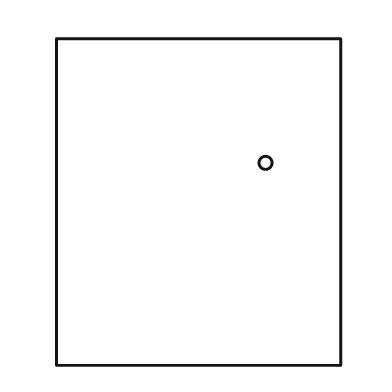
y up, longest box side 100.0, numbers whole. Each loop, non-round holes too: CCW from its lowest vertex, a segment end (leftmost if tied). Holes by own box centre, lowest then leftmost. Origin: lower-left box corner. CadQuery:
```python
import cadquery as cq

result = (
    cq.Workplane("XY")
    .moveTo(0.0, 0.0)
    .lineTo(87.0, 0.0)
    .lineTo(87.0, 100.0)
    .lineTo(0.0, 100.0)
    .close()
    .moveTo(64.0, 62.0)
    .circle(2.0)
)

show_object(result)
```